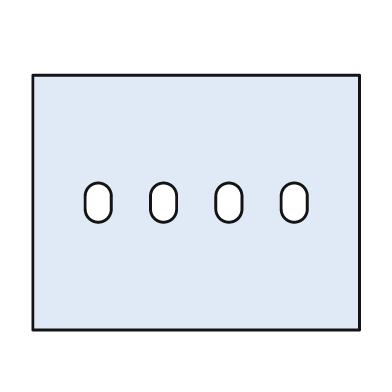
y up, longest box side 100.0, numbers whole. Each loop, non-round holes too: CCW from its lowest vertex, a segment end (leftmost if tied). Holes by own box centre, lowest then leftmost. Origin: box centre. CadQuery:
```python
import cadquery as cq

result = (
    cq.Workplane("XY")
    .moveTo(-50.0, -39.0)
    .lineTo(50.0, -39.0)
    .lineTo(50.0, 39.0)
    .lineTo(-50.0, 39.0)
    .close()
    .moveTo(-34.0, -2.0)
    .threePointArc((-30.0, -6.0), (-26.0, -2.0))
    .lineTo(-26.0, 2.0)
    .threePointArc((-30.0, 6.0), (-34.0, 2.0))
    .close()
    .moveTo(-14.0, -2.0)
    .threePointArc((-10.0, -6.0), (-6.0, -2.0))
    .lineTo(-6.0, 2.0)
    .threePointArc((-10.0, 6.0), (-14.0, 2.0))
    .close()
    .moveTo(6.0, -2.0)
    .threePointArc((10.0, -6.0), (14.0, -2.0))
    .lineTo(14.0, 2.0)
    .threePointArc((10.0, 6.0), (6.0, 2.0))
    .close()
    .moveTo(26.0, -2.0)
    .threePointArc((30.0, -6.0), (34.0, -2.0))
    .lineTo(34.0, 2.0)
    .threePointArc((30.0, 6.0), (26.0, 2.0))
    .close()
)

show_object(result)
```